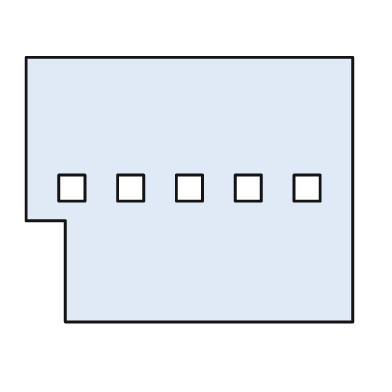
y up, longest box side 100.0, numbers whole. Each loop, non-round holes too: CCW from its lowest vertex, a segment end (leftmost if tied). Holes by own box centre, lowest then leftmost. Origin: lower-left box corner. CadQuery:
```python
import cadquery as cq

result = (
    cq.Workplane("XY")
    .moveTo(12.0, 0.0)
    .lineTo(100.0, 0.0)
    .lineTo(100.0, 81.0)
    .lineTo(0.0, 81.0)
    .lineTo(0.0, 31.0)
    .lineTo(12.0, 31.0)
    .close()
    .moveTo(10.0, 37.0)
    .lineTo(18.0, 37.0)
    .lineTo(18.0, 45.0)
    .lineTo(10.0, 45.0)
    .close()
    .moveTo(28.0, 37.0)
    .lineTo(36.0, 37.0)
    .lineTo(36.0, 45.0)
    .lineTo(28.0, 45.0)
    .close()
    .moveTo(46.0, 37.0)
    .lineTo(54.0, 37.0)
    .lineTo(54.0, 45.0)
    .lineTo(46.0, 45.0)
    .close()
    .moveTo(64.0, 37.0)
    .lineTo(72.0, 37.0)
    .lineTo(72.0, 45.0)
    .lineTo(64.0, 45.0)
    .close()
    .moveTo(82.0, 37.0)
    .lineTo(90.0, 37.0)
    .lineTo(90.0, 45.0)
    .lineTo(82.0, 45.0)
    .close()
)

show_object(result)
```